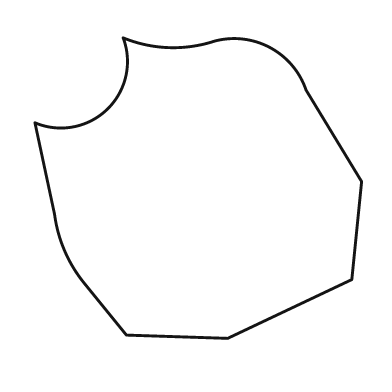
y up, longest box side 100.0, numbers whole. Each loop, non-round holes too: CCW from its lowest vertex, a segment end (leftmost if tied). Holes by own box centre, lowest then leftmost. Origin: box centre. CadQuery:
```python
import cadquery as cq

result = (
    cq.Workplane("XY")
    .moveTo(9.0, -46.0)
    .lineTo(47.0, -28.0)
    .lineTo(50.0, 2.0)
    .lineTo(33.0, 30.0)
    .threePointArc((22.0, 43.0), (5.0, 45.0))
    .threePointArc((-9.0, 43.0), (-23.0, 46.0))
    .threePointArc((-28.0, 24.0), (-50.0, 20.0))
    .lineTo(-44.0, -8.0)
    .threePointArc((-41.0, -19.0), (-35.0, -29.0))
    .lineTo(-22.0, -45.0)
    .close()
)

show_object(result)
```